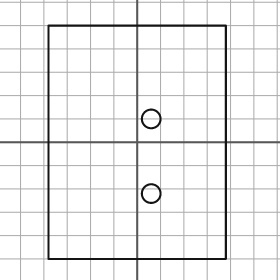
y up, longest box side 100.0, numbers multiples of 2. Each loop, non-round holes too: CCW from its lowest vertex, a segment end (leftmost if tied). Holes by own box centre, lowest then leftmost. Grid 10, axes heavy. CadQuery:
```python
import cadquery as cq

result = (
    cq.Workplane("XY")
    .moveTo(-38.0, -50.0)
    .lineTo(38.0, -50.0)
    .lineTo(38.0, 50.0)
    .lineTo(-38.0, 50.0)
    .close()
    .moveTo(6.0, -22.0)
    .circle(4.0)
    .moveTo(6.0, 10.0)
    .circle(4.0)
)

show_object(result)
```